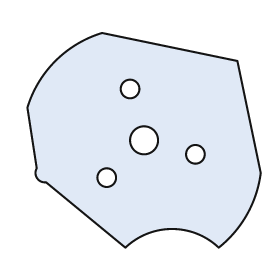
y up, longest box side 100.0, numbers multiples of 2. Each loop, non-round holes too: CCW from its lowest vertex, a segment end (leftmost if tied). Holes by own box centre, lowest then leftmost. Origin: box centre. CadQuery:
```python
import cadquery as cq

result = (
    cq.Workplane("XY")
    .moveTo(-8.0, -46.0)
    .threePointArc((12.0, -38.0), (32.0, -46.0))
    .threePointArc((44.0, -32.0), (50.0, -14.0))
    .lineTo(40.0, 34.0)
    .lineTo(-18.0, 46.0)
    .threePointArc((-38.0, 34.0), (-50.0, 14.0))
    .lineTo(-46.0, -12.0)
    .threePointArc((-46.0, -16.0), (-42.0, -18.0))
    .close()
    .moveTo(-16.0, -16.0)
    .circle(4.0)
    .moveTo(22.0, -6.0)
    .circle(4.0)
    .moveTo(0.0, 0.0)
    .circle(6.0)
    .moveTo(-6.0, 22.0)
    .circle(4.0)
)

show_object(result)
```